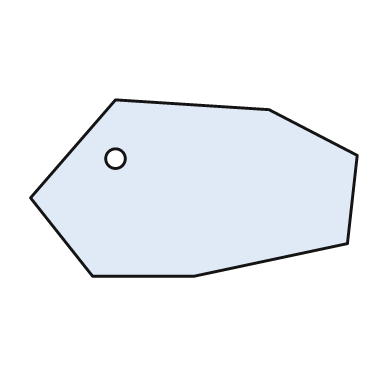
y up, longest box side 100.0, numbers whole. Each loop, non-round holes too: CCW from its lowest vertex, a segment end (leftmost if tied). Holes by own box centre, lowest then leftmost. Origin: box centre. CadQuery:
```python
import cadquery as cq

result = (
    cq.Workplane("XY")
    .moveTo(-31.0, -27.0)
    .lineTo(0.0, -27.0)
    .lineTo(47.0, -17.0)
    .lineTo(50.0, 10.0)
    .lineTo(23.0, 24.0)
    .lineTo(-24.0, 27.0)
    .lineTo(-50.0, -3.0)
    .close()
    .moveTo(-24.0, 9.0)
    .circle(3.0)
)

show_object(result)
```